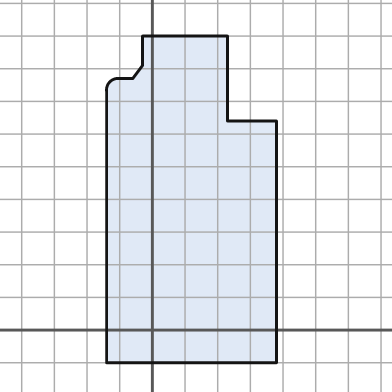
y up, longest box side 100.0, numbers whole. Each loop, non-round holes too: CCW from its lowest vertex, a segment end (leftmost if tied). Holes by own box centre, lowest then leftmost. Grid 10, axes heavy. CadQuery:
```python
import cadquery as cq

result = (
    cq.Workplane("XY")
    .moveTo(-14.0, -10.0)
    .lineTo(38.0, -10.0)
    .lineTo(38.0, 64.0)
    .lineTo(23.0, 64.0)
    .lineTo(23.0, 90.0)
    .lineTo(-3.0, 90.0)
    .lineTo(-3.0, 81.0)
    .lineTo(-6.0, 77.0)
    .lineTo(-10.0, 77.0)
    .threePointArc((-13.0, 76.0), (-14.0, 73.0))
    .close()
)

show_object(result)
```